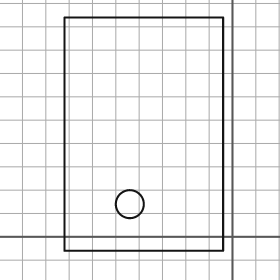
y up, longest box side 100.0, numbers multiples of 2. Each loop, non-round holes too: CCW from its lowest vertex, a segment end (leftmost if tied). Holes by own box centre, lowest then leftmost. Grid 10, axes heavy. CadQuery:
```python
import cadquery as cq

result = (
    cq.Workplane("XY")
    .moveTo(-72.0, -6.0)
    .lineTo(-4.0, -6.0)
    .lineTo(-4.0, 94.0)
    .lineTo(-72.0, 94.0)
    .close()
    .moveTo(-44.0, 14.0)
    .circle(6.0)
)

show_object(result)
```